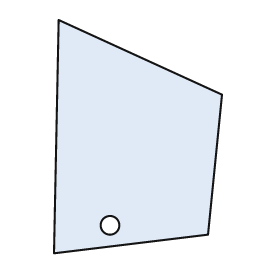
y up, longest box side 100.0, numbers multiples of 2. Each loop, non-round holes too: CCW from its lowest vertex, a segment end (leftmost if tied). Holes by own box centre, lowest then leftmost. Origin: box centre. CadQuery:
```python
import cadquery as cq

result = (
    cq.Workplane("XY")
    .moveTo(-36.0, -50.0)
    .lineTo(30.0, -42.0)
    .lineTo(36.0, 18.0)
    .lineTo(-34.0, 50.0)
    .close()
    .moveTo(-12.0, -38.0)
    .circle(4.0)
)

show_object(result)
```